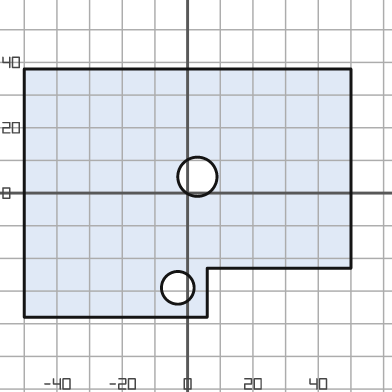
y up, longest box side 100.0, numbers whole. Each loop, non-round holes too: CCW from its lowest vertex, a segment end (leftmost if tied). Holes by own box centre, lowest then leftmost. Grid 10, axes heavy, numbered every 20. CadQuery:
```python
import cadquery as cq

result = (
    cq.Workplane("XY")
    .moveTo(-50.0, -38.0)
    .lineTo(6.0, -38.0)
    .lineTo(6.0, -23.0)
    .lineTo(50.0, -23.0)
    .lineTo(50.0, 38.0)
    .lineTo(-50.0, 38.0)
    .close()
    .moveTo(-3.0, -29.0)
    .circle(5.0)
    .moveTo(3.0, 5.0)
    .circle(6.0)
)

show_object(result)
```